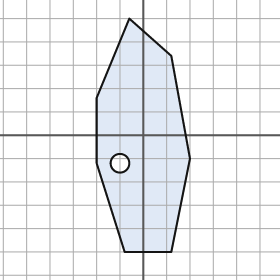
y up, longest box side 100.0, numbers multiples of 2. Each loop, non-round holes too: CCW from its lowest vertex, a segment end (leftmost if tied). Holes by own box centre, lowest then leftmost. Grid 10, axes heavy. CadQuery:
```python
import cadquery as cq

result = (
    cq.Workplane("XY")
    .moveTo(-8.0, -50.0)
    .lineTo(12.0, -50.0)
    .lineTo(20.0, -10.0)
    .lineTo(12.0, 34.0)
    .lineTo(-6.0, 50.0)
    .lineTo(-20.0, 16.0)
    .lineTo(-20.0, -12.0)
    .close()
    .moveTo(-10.0, -12.0)
    .circle(4.0)
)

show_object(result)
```